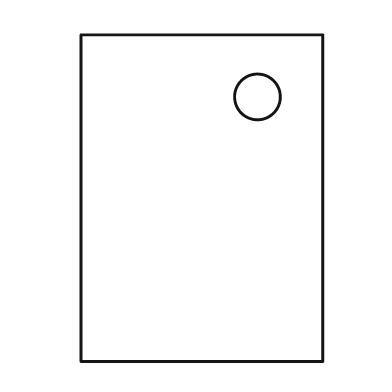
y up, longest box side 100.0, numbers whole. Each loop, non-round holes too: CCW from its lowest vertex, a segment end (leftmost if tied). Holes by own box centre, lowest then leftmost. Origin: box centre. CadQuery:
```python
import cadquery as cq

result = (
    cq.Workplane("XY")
    .moveTo(-37.0, -50.0)
    .lineTo(37.0, -50.0)
    .lineTo(37.0, 50.0)
    .lineTo(-37.0, 50.0)
    .close()
    .moveTo(17.0, 31.0)
    .circle(7.0)
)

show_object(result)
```